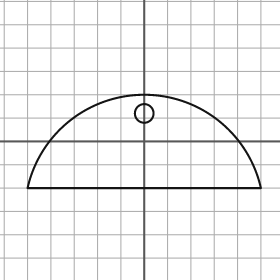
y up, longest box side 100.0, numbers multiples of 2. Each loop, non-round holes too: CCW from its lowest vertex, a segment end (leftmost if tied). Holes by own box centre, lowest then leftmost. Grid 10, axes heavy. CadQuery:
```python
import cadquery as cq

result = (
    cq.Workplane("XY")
    .moveTo(-50.0, -20.0)
    .lineTo(50.0, -20.0)
    .threePointArc((0.0, 20.0), (-50.0, -20.0))
    .close()
    .moveTo(0.0, 12.0)
    .circle(4.0)
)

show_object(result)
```